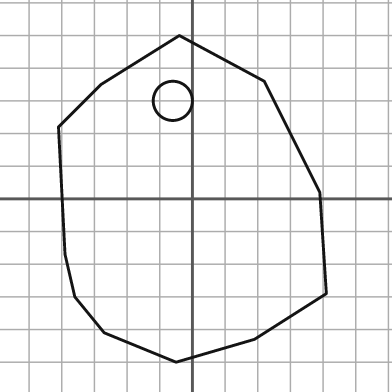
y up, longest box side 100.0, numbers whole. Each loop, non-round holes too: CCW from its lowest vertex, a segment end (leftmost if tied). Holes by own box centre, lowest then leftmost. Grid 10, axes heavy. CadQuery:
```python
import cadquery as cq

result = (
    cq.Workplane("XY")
    .moveTo(-5.0, -50.0)
    .lineTo(19.0, -43.0)
    .lineTo(41.0, -29.0)
    .lineTo(39.0, 2.0)
    .lineTo(22.0, 36.0)
    .lineTo(-4.0, 50.0)
    .lineTo(-28.0, 35.0)
    .lineTo(-41.0, 22.0)
    .lineTo(-39.0, -17.0)
    .lineTo(-36.0, -30.0)
    .lineTo(-27.0, -41.0)
    .close()
    .moveTo(-6.0, 30.0)
    .circle(6.0)
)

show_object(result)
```